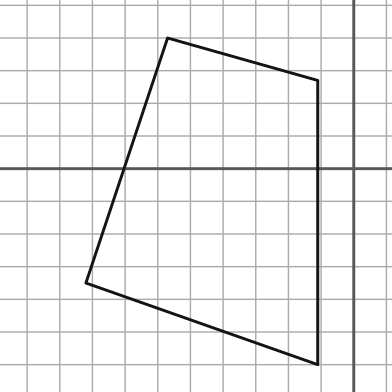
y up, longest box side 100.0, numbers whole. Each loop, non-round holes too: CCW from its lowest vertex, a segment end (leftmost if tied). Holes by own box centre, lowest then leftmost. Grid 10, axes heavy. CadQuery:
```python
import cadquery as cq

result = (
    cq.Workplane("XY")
    .moveTo(-11.0, -60.0)
    .lineTo(-11.0, 27.0)
    .lineTo(-57.0, 40.0)
    .lineTo(-82.0, -35.0)
    .close()
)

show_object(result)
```